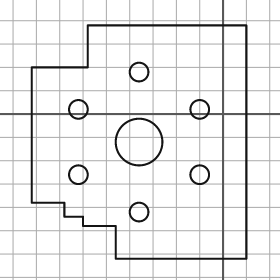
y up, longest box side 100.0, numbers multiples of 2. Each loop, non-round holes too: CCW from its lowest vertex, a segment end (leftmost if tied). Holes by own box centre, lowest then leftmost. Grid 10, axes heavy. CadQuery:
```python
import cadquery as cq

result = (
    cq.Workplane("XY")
    .moveTo(-46.0, -62.0)
    .lineTo(10.0, -62.0)
    .lineTo(10.0, 38.0)
    .lineTo(-58.0, 38.0)
    .lineTo(-58.0, 20.0)
    .lineTo(-82.0, 20.0)
    .lineTo(-82.0, -38.0)
    .lineTo(-68.0, -38.0)
    .lineTo(-68.0, -44.0)
    .lineTo(-60.0, -44.0)
    .lineTo(-60.0, -48.0)
    .lineTo(-46.0, -48.0)
    .close()
    .moveTo(-36.0, -42.0)
    .circle(4.0)
    .moveTo(-62.0, -26.0)
    .circle(4.0)
    .moveTo(-10.0, -26.0)
    .circle(4.0)
    .moveTo(-36.0, -12.0)
    .circle(10.0)
    .moveTo(-62.0, 2.0)
    .circle(4.0)
    .moveTo(-10.0, 2.0)
    .circle(4.0)
    .moveTo(-36.0, 18.0)
    .circle(4.0)
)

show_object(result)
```